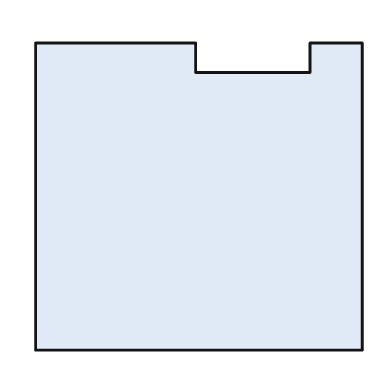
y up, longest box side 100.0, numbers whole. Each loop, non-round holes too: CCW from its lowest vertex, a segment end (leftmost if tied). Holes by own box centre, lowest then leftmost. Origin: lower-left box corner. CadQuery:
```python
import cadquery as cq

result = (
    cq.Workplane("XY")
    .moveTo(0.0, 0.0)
    .lineTo(100.0, 0.0)
    .lineTo(100.0, 94.0)
    .lineTo(84.0, 94.0)
    .lineTo(84.0, 85.0)
    .lineTo(49.0, 85.0)
    .lineTo(49.0, 94.0)
    .lineTo(0.0, 94.0)
    .close()
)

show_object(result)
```